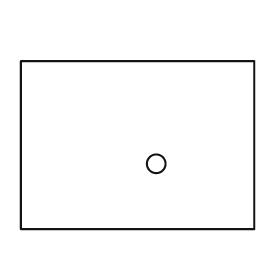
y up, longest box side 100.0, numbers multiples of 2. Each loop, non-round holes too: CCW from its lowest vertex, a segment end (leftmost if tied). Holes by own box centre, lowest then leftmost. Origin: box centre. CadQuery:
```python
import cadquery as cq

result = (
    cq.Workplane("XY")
    .moveTo(-50.0, -36.0)
    .lineTo(50.0, -36.0)
    .lineTo(50.0, 36.0)
    .lineTo(-50.0, 36.0)
    .close()
    .moveTo(8.0, -8.0)
    .circle(4.0)
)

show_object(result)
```